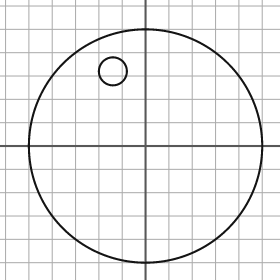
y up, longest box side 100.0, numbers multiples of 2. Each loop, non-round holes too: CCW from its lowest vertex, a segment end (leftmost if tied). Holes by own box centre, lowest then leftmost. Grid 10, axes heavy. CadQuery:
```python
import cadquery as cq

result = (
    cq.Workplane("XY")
    .moveTo(0.0, 0.0)
    .circle(50.0)
    .moveTo(-14.0, 32.0)
    .circle(6.0)
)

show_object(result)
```